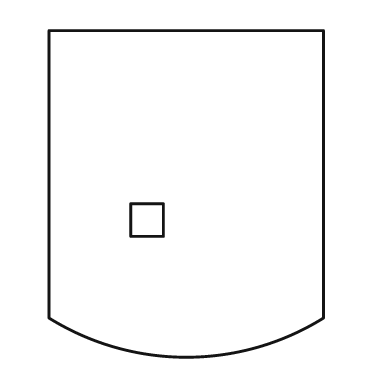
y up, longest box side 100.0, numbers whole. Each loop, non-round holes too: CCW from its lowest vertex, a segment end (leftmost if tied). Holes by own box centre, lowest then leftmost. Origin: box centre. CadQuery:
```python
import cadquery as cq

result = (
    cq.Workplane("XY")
    .moveTo(-42.0, -38.0)
    .threePointArc((0.0, -50.0), (42.0, -38.0))
    .lineTo(42.0, 50.0)
    .lineTo(-42.0, 50.0)
    .close()
    .moveTo(-17.0, -13.0)
    .lineTo(-7.0, -13.0)
    .lineTo(-7.0, -3.0)
    .lineTo(-17.0, -3.0)
    .close()
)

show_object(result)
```